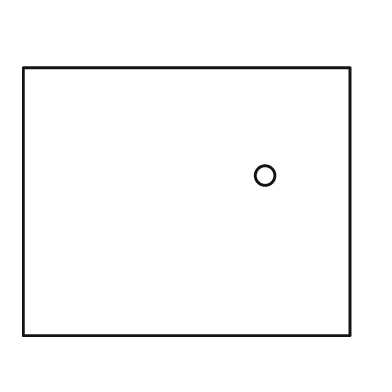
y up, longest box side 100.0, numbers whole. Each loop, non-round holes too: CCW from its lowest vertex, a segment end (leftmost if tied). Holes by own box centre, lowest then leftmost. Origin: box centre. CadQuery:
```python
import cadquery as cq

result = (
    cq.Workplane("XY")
    .moveTo(-50.0, -41.0)
    .lineTo(50.0, -41.0)
    .lineTo(50.0, 41.0)
    .lineTo(-50.0, 41.0)
    .close()
    .moveTo(24.0, 8.0)
    .circle(3.0)
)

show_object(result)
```